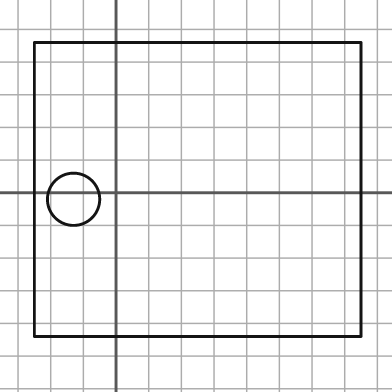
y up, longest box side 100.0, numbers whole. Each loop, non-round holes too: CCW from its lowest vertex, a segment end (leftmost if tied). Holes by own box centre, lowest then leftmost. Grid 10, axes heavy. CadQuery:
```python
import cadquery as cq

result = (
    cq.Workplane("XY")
    .moveTo(-25.0, -44.0)
    .lineTo(75.0, -44.0)
    .lineTo(75.0, 46.0)
    .lineTo(-25.0, 46.0)
    .close()
    .moveTo(-13.0, -2.0)
    .circle(8.0)
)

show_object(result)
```